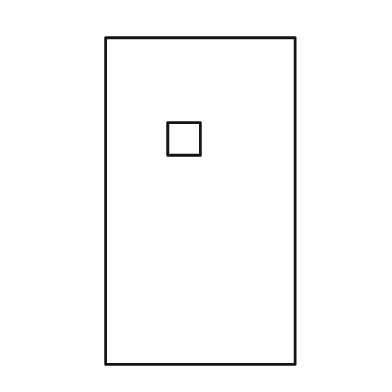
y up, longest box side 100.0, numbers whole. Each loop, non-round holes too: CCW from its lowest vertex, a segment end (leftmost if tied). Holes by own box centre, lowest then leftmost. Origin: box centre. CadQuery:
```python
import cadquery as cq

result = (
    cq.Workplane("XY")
    .moveTo(-29.0, -50.0)
    .lineTo(29.0, -50.0)
    .lineTo(29.0, 50.0)
    .lineTo(-29.0, 50.0)
    .close()
    .moveTo(-10.0, 14.0)
    .lineTo(0.0, 14.0)
    .lineTo(0.0, 24.0)
    .lineTo(-10.0, 24.0)
    .close()
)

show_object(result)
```